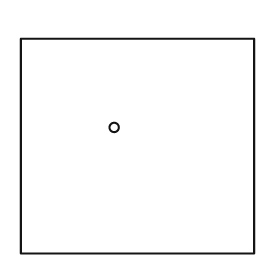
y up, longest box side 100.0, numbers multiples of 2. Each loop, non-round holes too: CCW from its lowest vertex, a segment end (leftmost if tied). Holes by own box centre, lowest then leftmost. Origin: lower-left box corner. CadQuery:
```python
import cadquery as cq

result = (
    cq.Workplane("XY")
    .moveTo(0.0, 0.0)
    .lineTo(100.0, 0.0)
    .lineTo(100.0, 92.0)
    .lineTo(0.0, 92.0)
    .close()
    .moveTo(40.0, 54.0)
    .circle(2.0)
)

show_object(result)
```